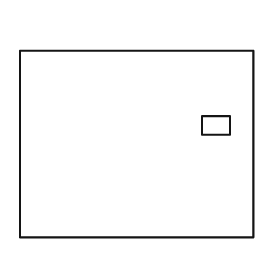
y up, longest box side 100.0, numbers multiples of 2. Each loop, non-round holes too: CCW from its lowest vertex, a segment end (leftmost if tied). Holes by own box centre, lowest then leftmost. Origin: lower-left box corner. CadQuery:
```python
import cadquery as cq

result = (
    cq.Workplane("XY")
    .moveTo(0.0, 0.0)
    .lineTo(100.0, 0.0)
    .lineTo(100.0, 80.0)
    .lineTo(0.0, 80.0)
    .close()
    .moveTo(78.0, 44.0)
    .lineTo(90.0, 44.0)
    .lineTo(90.0, 52.0)
    .lineTo(78.0, 52.0)
    .close()
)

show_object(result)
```